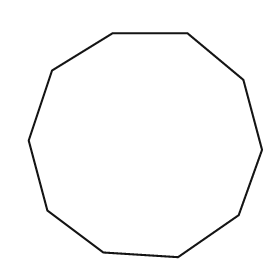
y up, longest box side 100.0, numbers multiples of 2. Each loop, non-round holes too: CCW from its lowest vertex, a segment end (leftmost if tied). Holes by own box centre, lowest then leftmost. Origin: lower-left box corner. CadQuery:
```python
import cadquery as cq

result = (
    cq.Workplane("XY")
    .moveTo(64.0, 0.0)
    .lineTo(90.0, 18.0)
    .lineTo(100.0, 46.0)
    .lineTo(92.0, 76.0)
    .lineTo(68.0, 96.0)
    .lineTo(36.0, 96.0)
    .lineTo(10.0, 80.0)
    .lineTo(0.0, 50.0)
    .lineTo(8.0, 20.0)
    .lineTo(32.0, 2.0)
    .close()
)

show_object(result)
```